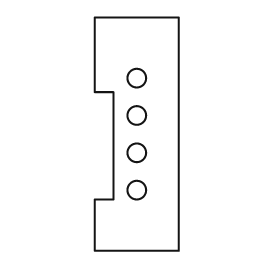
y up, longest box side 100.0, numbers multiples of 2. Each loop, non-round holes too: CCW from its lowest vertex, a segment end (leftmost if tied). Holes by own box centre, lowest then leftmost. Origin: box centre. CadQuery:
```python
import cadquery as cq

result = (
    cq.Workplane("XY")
    .moveTo(-18.0, -50.0)
    .lineTo(18.0, -50.0)
    .lineTo(18.0, 50.0)
    .lineTo(-18.0, 50.0)
    .lineTo(-18.0, 18.0)
    .lineTo(-10.0, 18.0)
    .lineTo(-10.0, -28.0)
    .lineTo(-18.0, -28.0)
    .close()
    .moveTo(0.0, -24.0)
    .circle(4.0)
    .moveTo(0.0, -8.0)
    .circle(4.0)
    .moveTo(0.0, 8.0)
    .circle(4.0)
    .moveTo(0.0, 24.0)
    .circle(4.0)
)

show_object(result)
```